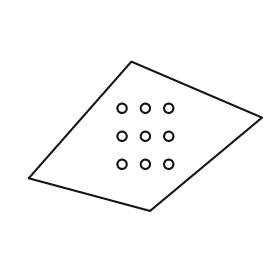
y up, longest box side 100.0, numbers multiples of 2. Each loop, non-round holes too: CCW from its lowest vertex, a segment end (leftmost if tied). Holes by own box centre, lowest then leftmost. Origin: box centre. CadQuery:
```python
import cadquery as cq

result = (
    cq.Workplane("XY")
    .moveTo(2.0, -32.0)
    .lineTo(50.0, 8.0)
    .lineTo(-6.0, 32.0)
    .lineTo(-50.0, -18.0)
    .close()
    .moveTo(-10.0, -12.0)
    .circle(2.0)
    .moveTo(0.0, -12.0)
    .circle(2.0)
    .moveTo(10.0, -12.0)
    .circle(2.0)
    .moveTo(-10.0, 0.0)
    .circle(2.0)
    .moveTo(0.0, 0.0)
    .circle(2.0)
    .moveTo(10.0, 0.0)
    .circle(2.0)
    .moveTo(-10.0, 12.0)
    .circle(2.0)
    .moveTo(0.0, 12.0)
    .circle(2.0)
    .moveTo(10.0, 12.0)
    .circle(2.0)
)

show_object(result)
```